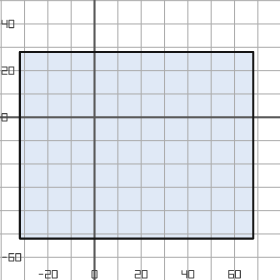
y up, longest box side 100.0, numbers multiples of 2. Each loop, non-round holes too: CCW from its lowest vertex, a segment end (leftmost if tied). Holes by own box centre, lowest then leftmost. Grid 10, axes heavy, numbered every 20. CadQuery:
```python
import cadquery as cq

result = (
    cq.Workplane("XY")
    .moveTo(-32.0, -52.0)
    .lineTo(68.0, -52.0)
    .lineTo(68.0, 28.0)
    .lineTo(-32.0, 28.0)
    .close()
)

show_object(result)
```